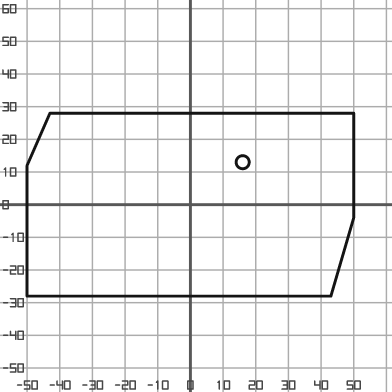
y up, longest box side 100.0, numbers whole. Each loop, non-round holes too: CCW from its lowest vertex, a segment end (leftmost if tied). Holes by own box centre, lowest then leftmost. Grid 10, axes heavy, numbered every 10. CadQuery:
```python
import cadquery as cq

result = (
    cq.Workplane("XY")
    .moveTo(-50.0, -28.0)
    .lineTo(43.0, -28.0)
    .lineTo(50.0, -4.0)
    .lineTo(50.0, 28.0)
    .lineTo(-43.0, 28.0)
    .lineTo(-50.0, 12.0)
    .close()
    .moveTo(16.0, 13.0)
    .circle(2.0)
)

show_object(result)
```